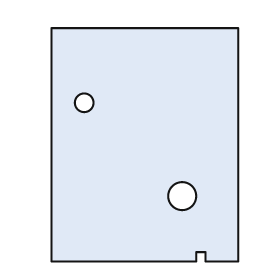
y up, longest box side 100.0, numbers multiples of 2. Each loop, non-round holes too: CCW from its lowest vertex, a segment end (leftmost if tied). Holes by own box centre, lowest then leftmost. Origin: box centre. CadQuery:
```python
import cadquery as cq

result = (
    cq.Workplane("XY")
    .moveTo(-40.0, -50.0)
    .lineTo(22.0, -50.0)
    .lineTo(22.0, -46.0)
    .lineTo(26.0, -46.0)
    .lineTo(26.0, -50.0)
    .lineTo(40.0, -50.0)
    .lineTo(40.0, 50.0)
    .lineTo(-40.0, 50.0)
    .close()
    .moveTo(16.0, -22.0)
    .circle(6.0)
    .moveTo(-26.0, 18.0)
    .circle(4.0)
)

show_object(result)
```